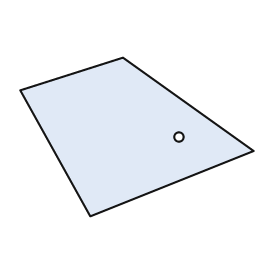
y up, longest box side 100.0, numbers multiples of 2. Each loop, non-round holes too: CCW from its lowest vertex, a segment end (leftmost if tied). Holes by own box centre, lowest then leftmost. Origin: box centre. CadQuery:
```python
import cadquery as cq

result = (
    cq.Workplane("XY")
    .moveTo(-20.0, -34.0)
    .lineTo(50.0, -6.0)
    .lineTo(-6.0, 34.0)
    .lineTo(-50.0, 20.0)
    .close()
    .moveTo(18.0, 0.0)
    .circle(2.0)
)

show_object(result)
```